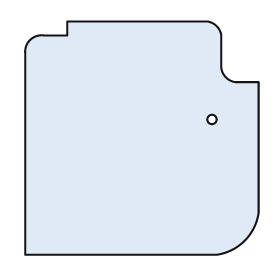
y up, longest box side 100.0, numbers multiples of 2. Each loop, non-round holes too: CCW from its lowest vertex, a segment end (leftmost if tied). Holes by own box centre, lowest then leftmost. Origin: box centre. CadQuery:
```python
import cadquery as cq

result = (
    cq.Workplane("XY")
    .moveTo(-50.0, -50.0)
    .lineTo(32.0, -50.0)
    .threePointArc((44.0, -44.0), (50.0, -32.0))
    .lineTo(50.0, 24.0)
    .lineTo(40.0, 24.0)
    .threePointArc((36.0, 26.0), (34.0, 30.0))
    .lineTo(34.0, 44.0)
    .threePointArc((32.0, 48.0), (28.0, 50.0))
    .lineTo(-32.0, 50.0)
    .lineTo(-32.0, 44.0)
    .lineTo(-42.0, 44.0)
    .threePointArc((-48.0, 42.0), (-50.0, 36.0))
    .close()
    .moveTo(30.0, 8.0)
    .circle(2.0)
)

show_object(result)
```